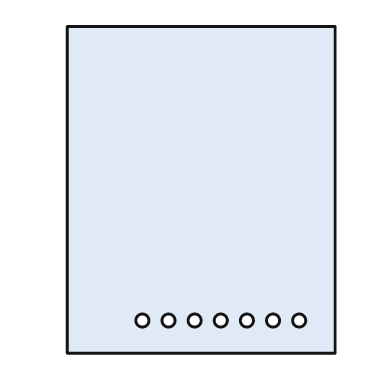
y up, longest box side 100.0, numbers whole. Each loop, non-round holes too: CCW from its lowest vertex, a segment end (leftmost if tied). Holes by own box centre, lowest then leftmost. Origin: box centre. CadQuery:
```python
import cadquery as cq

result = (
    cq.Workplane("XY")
    .moveTo(-41.0, -50.0)
    .lineTo(41.0, -50.0)
    .lineTo(41.0, 50.0)
    .lineTo(-41.0, 50.0)
    .close()
    .moveTo(-18.0, -40.0)
    .circle(2.0)
    .moveTo(-10.0, -40.0)
    .circle(2.0)
    .moveTo(-2.0, -40.0)
    .circle(2.0)
    .moveTo(6.0, -40.0)
    .circle(2.0)
    .moveTo(14.0, -40.0)
    .circle(2.0)
    .moveTo(22.0, -40.0)
    .circle(2.0)
    .moveTo(30.0, -40.0)
    .circle(2.0)
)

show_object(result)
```